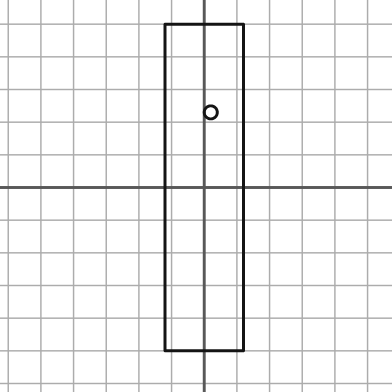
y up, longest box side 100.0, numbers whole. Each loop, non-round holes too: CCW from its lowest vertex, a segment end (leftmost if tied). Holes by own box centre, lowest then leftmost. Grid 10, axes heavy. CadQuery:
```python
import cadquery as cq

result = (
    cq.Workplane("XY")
    .moveTo(-12.0, -50.0)
    .lineTo(12.0, -50.0)
    .lineTo(12.0, 50.0)
    .lineTo(-12.0, 50.0)
    .close()
    .moveTo(2.0, 23.0)
    .circle(2.0)
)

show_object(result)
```